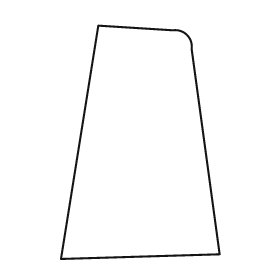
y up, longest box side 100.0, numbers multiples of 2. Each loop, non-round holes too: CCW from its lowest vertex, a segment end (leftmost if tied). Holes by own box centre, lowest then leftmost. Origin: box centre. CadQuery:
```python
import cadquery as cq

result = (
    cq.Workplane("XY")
    .moveTo(-34.0, -50.0)
    .lineTo(34.0, -48.0)
    .lineTo(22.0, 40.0)
    .threePointArc((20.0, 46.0), (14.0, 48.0))
    .lineTo(-18.0, 50.0)
    .close()
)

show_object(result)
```